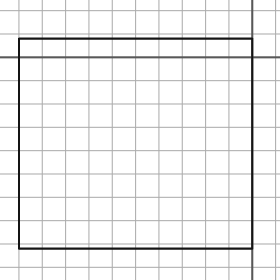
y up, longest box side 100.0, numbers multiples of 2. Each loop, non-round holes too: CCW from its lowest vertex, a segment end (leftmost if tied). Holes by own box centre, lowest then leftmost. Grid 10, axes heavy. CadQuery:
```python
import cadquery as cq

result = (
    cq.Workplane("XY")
    .moveTo(-100.0, -82.0)
    .lineTo(0.0, -82.0)
    .lineTo(0.0, 8.0)
    .lineTo(-100.0, 8.0)
    .close()
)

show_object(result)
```